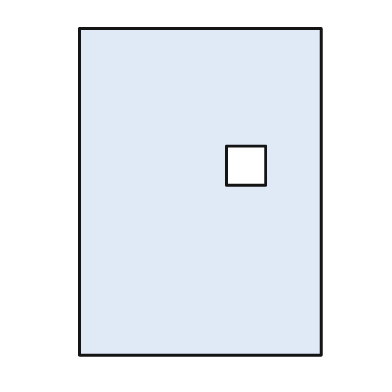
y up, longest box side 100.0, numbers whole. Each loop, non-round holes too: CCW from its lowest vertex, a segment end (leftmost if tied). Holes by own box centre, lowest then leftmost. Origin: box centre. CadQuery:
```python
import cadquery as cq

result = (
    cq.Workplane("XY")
    .moveTo(-37.0, -50.0)
    .lineTo(37.0, -50.0)
    .lineTo(37.0, 50.0)
    .lineTo(-37.0, 50.0)
    .close()
    .moveTo(8.0, 2.0)
    .lineTo(20.0, 2.0)
    .lineTo(20.0, 14.0)
    .lineTo(8.0, 14.0)
    .close()
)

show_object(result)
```